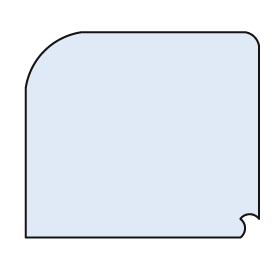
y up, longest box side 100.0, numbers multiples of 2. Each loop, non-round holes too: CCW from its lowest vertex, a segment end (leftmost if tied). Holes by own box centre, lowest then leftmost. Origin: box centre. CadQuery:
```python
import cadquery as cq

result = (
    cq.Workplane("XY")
    .moveTo(-50.0, -44.0)
    .lineTo(42.0, -44.0)
    .threePointArc((44.0, -40.0), (42.0, -36.0))
    .threePointArc((46.0, -34.0), (50.0, -36.0))
    .lineTo(50.0, 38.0)
    .threePointArc((48.0, 42.0), (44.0, 44.0))
    .lineTo(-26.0, 44.0)
    .threePointArc((-42.0, 36.0), (-50.0, 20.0))
    .close()
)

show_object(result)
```